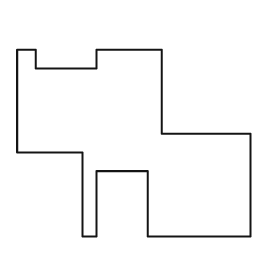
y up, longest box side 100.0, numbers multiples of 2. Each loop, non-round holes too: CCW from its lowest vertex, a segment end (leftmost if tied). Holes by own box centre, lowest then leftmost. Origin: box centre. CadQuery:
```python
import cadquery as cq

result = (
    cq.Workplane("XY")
    .moveTo(-22.0, -40.0)
    .lineTo(-16.0, -40.0)
    .lineTo(-16.0, -12.0)
    .lineTo(6.0, -12.0)
    .lineTo(6.0, -40.0)
    .lineTo(50.0, -40.0)
    .lineTo(50.0, 4.0)
    .lineTo(12.0, 4.0)
    .lineTo(12.0, 40.0)
    .lineTo(-16.0, 40.0)
    .lineTo(-16.0, 32.0)
    .lineTo(-42.0, 32.0)
    .lineTo(-42.0, 40.0)
    .lineTo(-50.0, 40.0)
    .lineTo(-50.0, -4.0)
    .lineTo(-22.0, -4.0)
    .close()
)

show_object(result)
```